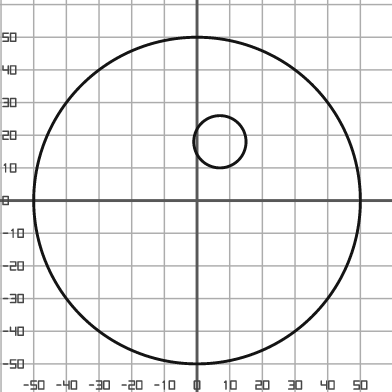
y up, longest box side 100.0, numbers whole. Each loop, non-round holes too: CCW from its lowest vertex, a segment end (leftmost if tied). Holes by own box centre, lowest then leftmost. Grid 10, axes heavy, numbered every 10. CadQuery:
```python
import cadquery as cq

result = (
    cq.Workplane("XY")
    .moveTo(0.0, 0.0)
    .circle(50.0)
    .moveTo(7.0, 18.0)
    .circle(8.0)
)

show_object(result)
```